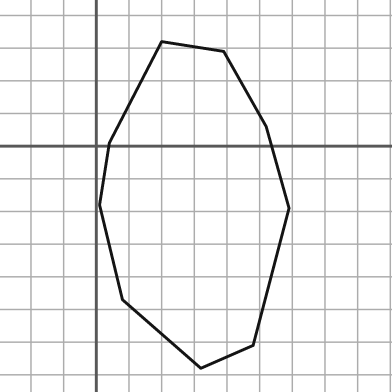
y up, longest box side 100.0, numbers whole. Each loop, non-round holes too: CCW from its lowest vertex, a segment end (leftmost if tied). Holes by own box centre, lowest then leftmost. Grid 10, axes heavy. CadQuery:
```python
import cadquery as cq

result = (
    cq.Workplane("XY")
    .moveTo(32.0, -68.0)
    .lineTo(48.0, -61.0)
    .lineTo(59.0, -19.0)
    .lineTo(52.0, 6.0)
    .lineTo(39.0, 29.0)
    .lineTo(20.0, 32.0)
    .lineTo(4.0, 1.0)
    .lineTo(1.0, -18.0)
    .lineTo(8.0, -47.0)
    .close()
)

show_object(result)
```